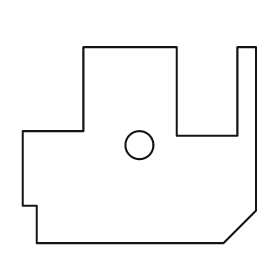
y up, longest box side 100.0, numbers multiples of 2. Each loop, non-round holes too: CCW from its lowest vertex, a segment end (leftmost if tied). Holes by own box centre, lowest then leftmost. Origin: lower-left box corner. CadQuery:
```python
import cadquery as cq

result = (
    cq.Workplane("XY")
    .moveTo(6.0, 0.0)
    .lineTo(86.0, 0.0)
    .lineTo(100.0, 14.0)
    .lineTo(100.0, 84.0)
    .lineTo(92.0, 84.0)
    .lineTo(92.0, 46.0)
    .lineTo(66.0, 46.0)
    .lineTo(66.0, 84.0)
    .lineTo(26.0, 84.0)
    .lineTo(26.0, 48.0)
    .lineTo(0.0, 48.0)
    .lineTo(0.0, 16.0)
    .lineTo(6.0, 16.0)
    .close()
    .moveTo(50.0, 42.0)
    .circle(6.0)
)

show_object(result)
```